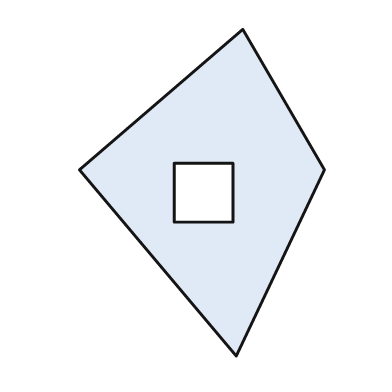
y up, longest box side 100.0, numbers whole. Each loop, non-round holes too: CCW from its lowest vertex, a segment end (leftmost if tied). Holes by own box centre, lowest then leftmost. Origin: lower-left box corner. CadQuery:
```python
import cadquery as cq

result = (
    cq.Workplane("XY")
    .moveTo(48.0, 0.0)
    .lineTo(75.0, 57.0)
    .lineTo(50.0, 100.0)
    .lineTo(0.0, 57.0)
    .close()
    .moveTo(29.0, 41.0)
    .lineTo(47.0, 41.0)
    .lineTo(47.0, 59.0)
    .lineTo(29.0, 59.0)
    .close()
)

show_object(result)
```